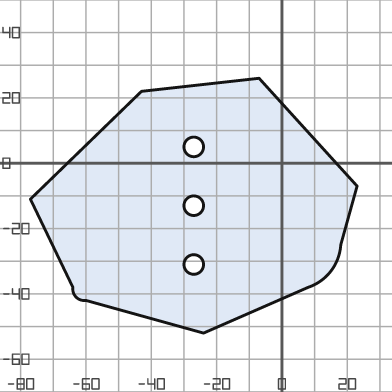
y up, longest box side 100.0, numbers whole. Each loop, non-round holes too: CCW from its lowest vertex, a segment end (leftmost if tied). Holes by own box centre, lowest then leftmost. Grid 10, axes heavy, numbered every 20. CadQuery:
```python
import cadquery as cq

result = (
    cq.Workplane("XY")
    .moveTo(-24.0, -52.0)
    .lineTo(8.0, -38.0)
    .threePointArc((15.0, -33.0), (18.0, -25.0))
    .lineTo(23.0, -7.0)
    .lineTo(-7.0, 26.0)
    .lineTo(-43.0, 22.0)
    .lineTo(-77.0, -11.0)
    .lineTo(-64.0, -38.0)
    .threePointArc((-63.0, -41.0), (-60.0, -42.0))
    .close()
    .moveTo(-27.0, -31.0)
    .circle(3.0)
    .moveTo(-27.0, -13.0)
    .circle(3.0)
    .moveTo(-27.0, 5.0)
    .circle(3.0)
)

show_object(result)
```